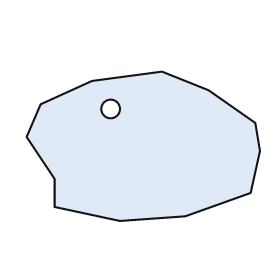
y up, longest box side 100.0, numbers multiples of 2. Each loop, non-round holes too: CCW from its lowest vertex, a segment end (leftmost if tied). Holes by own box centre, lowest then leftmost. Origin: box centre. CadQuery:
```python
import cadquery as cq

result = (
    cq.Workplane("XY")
    .moveTo(-10.0, -32.0)
    .lineTo(18.0, -30.0)
    .lineTo(46.0, -20.0)
    .lineTo(50.0, -2.0)
    .lineTo(48.0, 10.0)
    .lineTo(28.0, 24.0)
    .lineTo(8.0, 32.0)
    .lineTo(-22.0, 28.0)
    .lineTo(-44.0, 18.0)
    .lineTo(-50.0, 4.0)
    .lineTo(-38.0, -14.0)
    .lineTo(-38.0, -26.0)
    .close()
    .moveTo(-14.0, 16.0)
    .circle(4.0)
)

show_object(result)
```